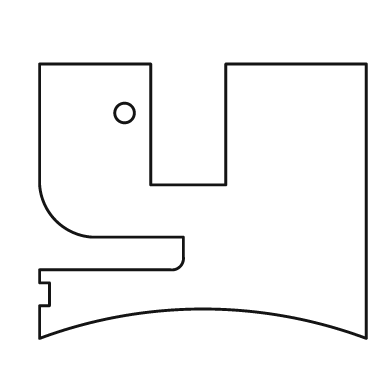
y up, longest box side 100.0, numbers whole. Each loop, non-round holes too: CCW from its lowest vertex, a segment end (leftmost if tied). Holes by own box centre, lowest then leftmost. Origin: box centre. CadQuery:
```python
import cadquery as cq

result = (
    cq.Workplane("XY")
    .moveTo(-50.0, -42.0)
    .threePointArc((0.0, -33.0), (50.0, -42.0))
    .lineTo(50.0, 42.0)
    .lineTo(7.0, 42.0)
    .lineTo(7.0, 5.0)
    .lineTo(-16.0, 5.0)
    .lineTo(-16.0, 42.0)
    .lineTo(-50.0, 42.0)
    .lineTo(-50.0, 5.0)
    .threePointArc((-45.0, -6.0), (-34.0, -11.0))
    .lineTo(-6.0, -11.0)
    .lineTo(-6.0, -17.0)
    .threePointArc((-7.0, -20.0), (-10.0, -21.0))
    .lineTo(-50.0, -21.0)
    .lineTo(-50.0, -25.0)
    .lineTo(-47.0, -25.0)
    .lineTo(-47.0, -32.0)
    .lineTo(-50.0, -32.0)
    .close()
    .moveTo(-24.0, 27.0)
    .circle(3.0)
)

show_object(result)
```